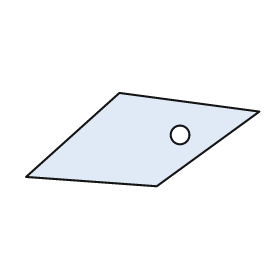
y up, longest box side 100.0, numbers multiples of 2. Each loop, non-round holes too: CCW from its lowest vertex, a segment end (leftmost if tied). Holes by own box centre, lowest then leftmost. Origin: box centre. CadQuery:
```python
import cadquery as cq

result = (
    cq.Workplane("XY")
    .moveTo(6.0, -20.0)
    .lineTo(50.0, 12.0)
    .lineTo(-10.0, 20.0)
    .lineTo(-50.0, -16.0)
    .close()
    .moveTo(16.0, 2.0)
    .circle(4.0)
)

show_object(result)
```